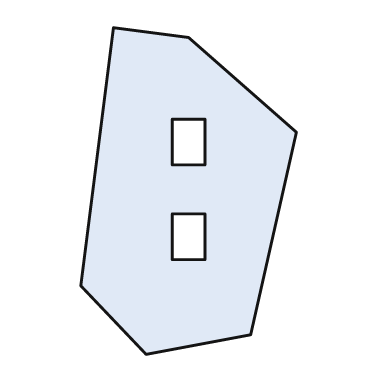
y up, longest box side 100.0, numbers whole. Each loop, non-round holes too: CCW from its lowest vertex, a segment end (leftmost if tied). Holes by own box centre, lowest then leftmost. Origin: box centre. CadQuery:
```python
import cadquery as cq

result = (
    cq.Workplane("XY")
    .moveTo(-13.0, -50.0)
    .lineTo(19.0, -44.0)
    .lineTo(33.0, 18.0)
    .lineTo(0.0, 47.0)
    .lineTo(-23.0, 50.0)
    .lineTo(-33.0, -29.0)
    .close()
    .moveTo(-5.0, -21.0)
    .lineTo(5.0, -21.0)
    .lineTo(5.0, -7.0)
    .lineTo(-5.0, -7.0)
    .close()
    .moveTo(-5.0, 8.0)
    .lineTo(5.0, 8.0)
    .lineTo(5.0, 22.0)
    .lineTo(-5.0, 22.0)
    .close()
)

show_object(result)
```